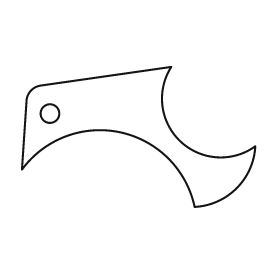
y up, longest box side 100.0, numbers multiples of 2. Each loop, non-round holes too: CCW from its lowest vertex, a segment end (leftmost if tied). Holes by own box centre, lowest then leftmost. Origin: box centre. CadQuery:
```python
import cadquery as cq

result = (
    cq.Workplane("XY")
    .moveTo(24.0, -30.0)
    .threePointArc((42.0, -22.0), (50.0, -4.0))
    .threePointArc((18.0, -2.0), (14.0, 30.0))
    .lineTo(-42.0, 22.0)
    .threePointArc((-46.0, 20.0), (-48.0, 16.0))
    .lineTo(-50.0, -14.0)
    .threePointArc((-8.0, 2.0), (24.0, -30.0))
    .close()
    .moveTo(-38.0, 10.0)
    .circle(4.0)
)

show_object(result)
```